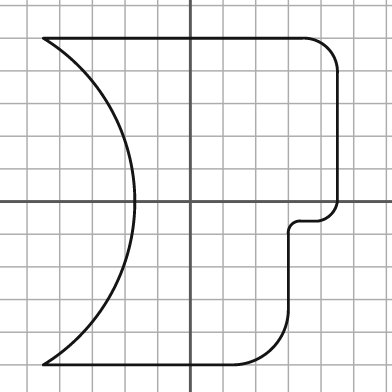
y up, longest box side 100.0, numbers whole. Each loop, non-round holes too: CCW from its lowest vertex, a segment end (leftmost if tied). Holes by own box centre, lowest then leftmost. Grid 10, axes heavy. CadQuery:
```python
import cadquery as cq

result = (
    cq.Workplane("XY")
    .moveTo(-45.0, -50.0)
    .lineTo(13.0, -50.0)
    .threePointArc((25.0, -45.0), (30.0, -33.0))
    .lineTo(30.0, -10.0)
    .threePointArc((31.0, -7.0), (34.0, -6.0))
    .lineTo(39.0, -6.0)
    .threePointArc((43.0, -4.0), (45.0, 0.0))
    .lineTo(45.0, 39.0)
    .threePointArc((42.0, 47.0), (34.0, 50.0))
    .lineTo(-45.0, 50.0)
    .threePointArc((-17.0, 0.0), (-45.0, -50.0))
    .close()
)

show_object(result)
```